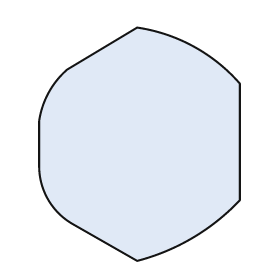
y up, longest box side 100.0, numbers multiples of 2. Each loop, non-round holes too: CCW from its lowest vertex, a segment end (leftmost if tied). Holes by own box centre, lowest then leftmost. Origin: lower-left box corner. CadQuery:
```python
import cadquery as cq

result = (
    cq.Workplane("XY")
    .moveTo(42.0, 0.0)
    .threePointArc((66.0, 10.0), (86.0, 26.0))
    .lineTo(86.0, 76.0)
    .threePointArc((66.0, 92.0), (42.0, 100.0))
    .lineTo(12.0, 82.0)
    .threePointArc((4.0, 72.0), (0.0, 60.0))
    .lineTo(0.0, 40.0)
    .threePointArc((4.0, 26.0), (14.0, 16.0))
    .close()
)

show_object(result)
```